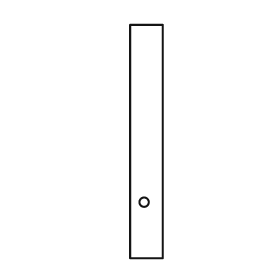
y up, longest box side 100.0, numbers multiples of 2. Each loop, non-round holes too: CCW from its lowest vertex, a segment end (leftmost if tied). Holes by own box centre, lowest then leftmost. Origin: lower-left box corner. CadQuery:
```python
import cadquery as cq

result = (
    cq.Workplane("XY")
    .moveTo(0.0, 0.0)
    .lineTo(14.0, 0.0)
    .lineTo(14.0, 100.0)
    .lineTo(0.0, 100.0)
    .close()
    .moveTo(6.0, 24.0)
    .circle(2.0)
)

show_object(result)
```